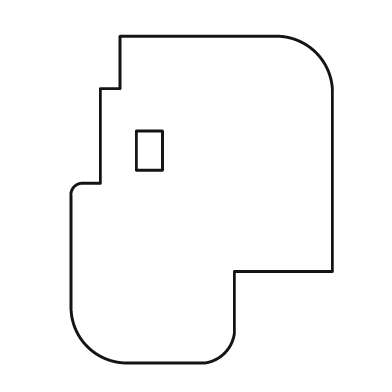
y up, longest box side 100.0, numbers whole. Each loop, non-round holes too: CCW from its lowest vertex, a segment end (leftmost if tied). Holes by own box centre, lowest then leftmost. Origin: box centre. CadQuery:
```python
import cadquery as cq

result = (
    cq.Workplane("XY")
    .moveTo(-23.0, -50.0)
    .lineTo(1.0, -50.0)
    .threePointArc((7.0, -47.0), (10.0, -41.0))
    .lineTo(10.0, -22.0)
    .lineTo(40.0, -22.0)
    .lineTo(40.0, 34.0)
    .threePointArc((35.0, 45.0), (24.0, 50.0))
    .lineTo(-25.0, 50.0)
    .lineTo(-25.0, 34.0)
    .lineTo(-31.0, 34.0)
    .lineTo(-31.0, 5.0)
    .lineTo(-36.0, 5.0)
    .threePointArc((-39.0, 4.0), (-40.0, 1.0))
    .lineTo(-40.0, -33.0)
    .threePointArc((-35.0, -45.0), (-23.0, -50.0))
    .close()
    .moveTo(-20.0, 9.0)
    .lineTo(-12.0, 9.0)
    .lineTo(-12.0, 21.0)
    .lineTo(-20.0, 21.0)
    .close()
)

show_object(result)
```